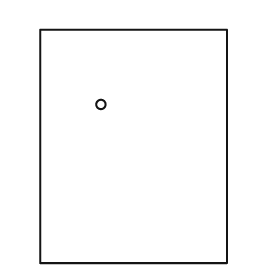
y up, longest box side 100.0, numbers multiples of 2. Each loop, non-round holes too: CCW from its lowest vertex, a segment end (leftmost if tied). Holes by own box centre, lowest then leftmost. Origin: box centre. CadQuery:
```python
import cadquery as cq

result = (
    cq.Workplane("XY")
    .moveTo(-40.0, -50.0)
    .lineTo(40.0, -50.0)
    .lineTo(40.0, 50.0)
    .lineTo(-40.0, 50.0)
    .close()
    .moveTo(-14.0, 18.0)
    .circle(2.0)
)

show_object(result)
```